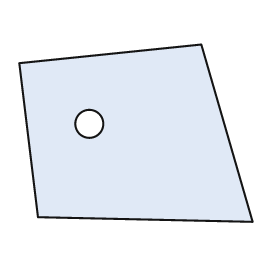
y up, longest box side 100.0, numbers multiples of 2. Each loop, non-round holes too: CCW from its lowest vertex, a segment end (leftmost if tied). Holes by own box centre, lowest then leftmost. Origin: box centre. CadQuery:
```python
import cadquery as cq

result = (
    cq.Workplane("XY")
    .moveTo(50.0, -38.0)
    .lineTo(28.0, 38.0)
    .lineTo(-50.0, 30.0)
    .lineTo(-42.0, -36.0)
    .close()
    .moveTo(-20.0, 4.0)
    .circle(6.0)
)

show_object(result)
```